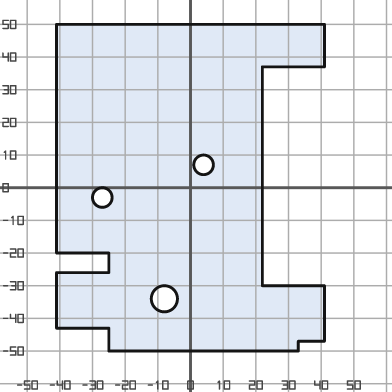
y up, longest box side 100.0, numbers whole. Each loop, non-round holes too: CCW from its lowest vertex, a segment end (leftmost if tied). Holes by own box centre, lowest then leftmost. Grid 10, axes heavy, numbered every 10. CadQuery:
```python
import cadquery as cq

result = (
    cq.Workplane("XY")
    .moveTo(-25.0, -50.0)
    .lineTo(33.0, -50.0)
    .lineTo(33.0, -47.0)
    .lineTo(41.0, -47.0)
    .lineTo(41.0, -30.0)
    .lineTo(22.0, -30.0)
    .lineTo(22.0, 37.0)
    .lineTo(41.0, 37.0)
    .lineTo(41.0, 50.0)
    .lineTo(-41.0, 50.0)
    .lineTo(-41.0, -20.0)
    .lineTo(-25.0, -20.0)
    .lineTo(-25.0, -26.0)
    .lineTo(-41.0, -26.0)
    .lineTo(-41.0, -43.0)
    .lineTo(-25.0, -43.0)
    .close()
    .moveTo(-8.0, -34.0)
    .circle(4.0)
    .moveTo(-27.0, -3.0)
    .circle(3.0)
    .moveTo(4.0, 7.0)
    .circle(3.0)
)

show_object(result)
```